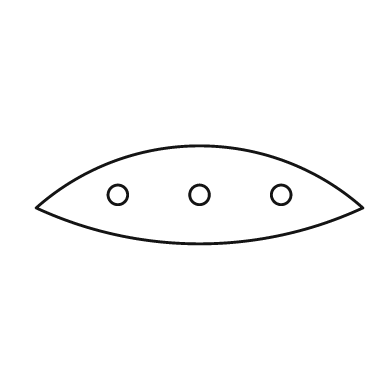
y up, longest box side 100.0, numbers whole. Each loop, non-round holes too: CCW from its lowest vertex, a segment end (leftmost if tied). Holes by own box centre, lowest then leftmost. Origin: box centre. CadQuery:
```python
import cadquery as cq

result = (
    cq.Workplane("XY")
    .moveTo(-50.0, -4.0)
    .threePointArc((0.0, -15.0), (50.0, -4.0))
    .threePointArc((0.0, 15.0), (-50.0, -4.0))
    .close()
    .moveTo(-25.0, 0.0)
    .circle(3.0)
    .moveTo(0.0, 0.0)
    .circle(3.0)
    .moveTo(25.0, 0.0)
    .circle(3.0)
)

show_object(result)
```